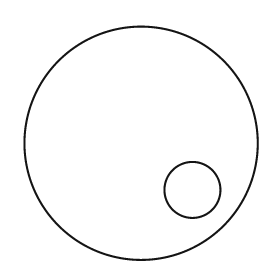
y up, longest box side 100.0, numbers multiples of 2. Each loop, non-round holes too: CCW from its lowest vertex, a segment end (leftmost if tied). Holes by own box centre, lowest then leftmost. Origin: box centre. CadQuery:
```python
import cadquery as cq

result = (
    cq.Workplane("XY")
    .moveTo(0.0, 0.0)
    .circle(50.0)
    .moveTo(22.0, -20.0)
    .circle(12.0)
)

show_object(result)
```